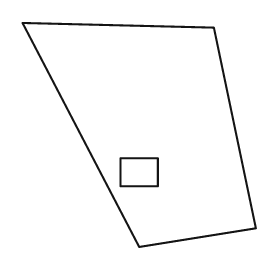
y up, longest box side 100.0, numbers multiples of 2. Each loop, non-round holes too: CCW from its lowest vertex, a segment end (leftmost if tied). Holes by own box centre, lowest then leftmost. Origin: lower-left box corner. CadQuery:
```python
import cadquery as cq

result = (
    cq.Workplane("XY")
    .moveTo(50.0, 0.0)
    .lineTo(100.0, 8.0)
    .lineTo(82.0, 94.0)
    .lineTo(0.0, 96.0)
    .close()
    .moveTo(42.0, 26.0)
    .lineTo(58.0, 26.0)
    .lineTo(58.0, 38.0)
    .lineTo(42.0, 38.0)
    .close()
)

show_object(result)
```